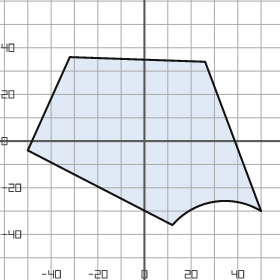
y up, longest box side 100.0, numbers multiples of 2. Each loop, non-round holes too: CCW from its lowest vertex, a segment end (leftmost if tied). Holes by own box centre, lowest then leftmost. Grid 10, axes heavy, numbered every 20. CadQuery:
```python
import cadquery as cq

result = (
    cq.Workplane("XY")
    .moveTo(12.0, -36.0)
    .threePointArc((30.0, -26.0), (50.0, -30.0))
    .lineTo(26.0, 34.0)
    .lineTo(-32.0, 36.0)
    .lineTo(-50.0, -4.0)
    .close()
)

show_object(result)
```